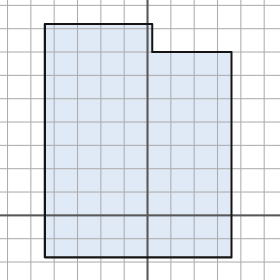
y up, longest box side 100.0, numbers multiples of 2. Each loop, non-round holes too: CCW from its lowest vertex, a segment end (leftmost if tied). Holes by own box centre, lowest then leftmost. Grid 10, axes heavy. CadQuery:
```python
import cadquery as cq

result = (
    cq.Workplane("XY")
    .moveTo(-44.0, -18.0)
    .lineTo(36.0, -18.0)
    .lineTo(36.0, 70.0)
    .lineTo(2.0, 70.0)
    .lineTo(2.0, 82.0)
    .lineTo(-44.0, 82.0)
    .close()
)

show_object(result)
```